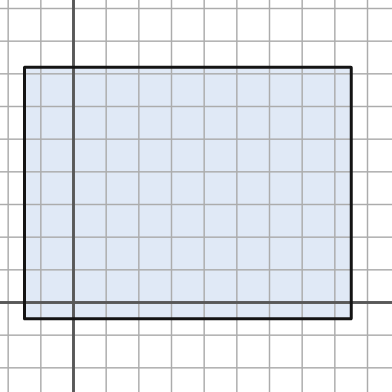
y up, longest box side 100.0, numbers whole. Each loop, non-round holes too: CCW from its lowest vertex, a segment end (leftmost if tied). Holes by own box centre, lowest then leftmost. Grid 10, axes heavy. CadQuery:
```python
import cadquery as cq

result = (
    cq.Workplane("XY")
    .moveTo(-15.0, -5.0)
    .lineTo(85.0, -5.0)
    .lineTo(85.0, 72.0)
    .lineTo(-15.0, 72.0)
    .close()
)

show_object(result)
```